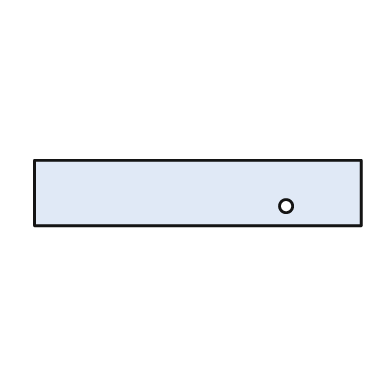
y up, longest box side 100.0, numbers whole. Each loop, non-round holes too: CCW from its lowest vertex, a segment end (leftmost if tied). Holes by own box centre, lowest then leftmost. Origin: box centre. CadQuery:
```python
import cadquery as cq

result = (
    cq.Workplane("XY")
    .moveTo(-50.0, -10.0)
    .lineTo(50.0, -10.0)
    .lineTo(50.0, 10.0)
    .lineTo(-50.0, 10.0)
    .close()
    .moveTo(27.0, -4.0)
    .circle(2.0)
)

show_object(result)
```